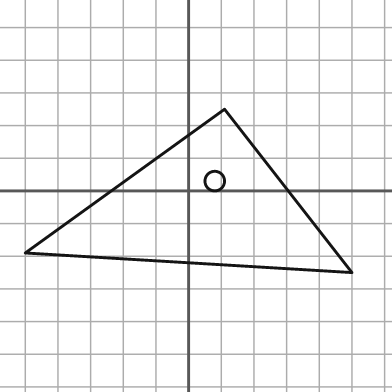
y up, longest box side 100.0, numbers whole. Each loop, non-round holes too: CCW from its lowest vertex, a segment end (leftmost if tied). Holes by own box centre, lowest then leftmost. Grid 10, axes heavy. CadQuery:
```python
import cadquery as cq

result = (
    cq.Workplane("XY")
    .moveTo(50.0, -25.0)
    .lineTo(11.0, 25.0)
    .lineTo(-50.0, -19.0)
    .close()
    .moveTo(8.0, 3.0)
    .circle(3.0)
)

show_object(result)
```